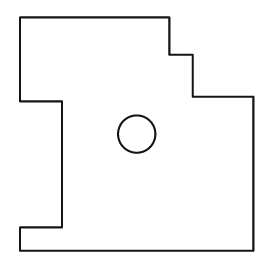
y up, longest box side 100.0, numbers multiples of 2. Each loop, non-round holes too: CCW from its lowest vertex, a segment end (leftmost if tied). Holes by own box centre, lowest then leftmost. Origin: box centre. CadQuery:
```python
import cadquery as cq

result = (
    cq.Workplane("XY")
    .moveTo(-50.0, -50.0)
    .lineTo(50.0, -50.0)
    .lineTo(50.0, 16.0)
    .lineTo(24.0, 16.0)
    .lineTo(24.0, 34.0)
    .lineTo(14.0, 34.0)
    .lineTo(14.0, 50.0)
    .lineTo(-50.0, 50.0)
    .lineTo(-50.0, 14.0)
    .lineTo(-32.0, 14.0)
    .lineTo(-32.0, -40.0)
    .lineTo(-50.0, -40.0)
    .close()
    .moveTo(0.0, 0.0)
    .circle(8.0)
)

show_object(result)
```